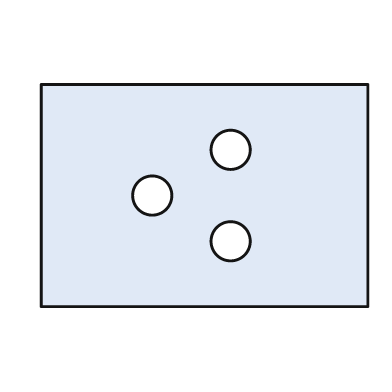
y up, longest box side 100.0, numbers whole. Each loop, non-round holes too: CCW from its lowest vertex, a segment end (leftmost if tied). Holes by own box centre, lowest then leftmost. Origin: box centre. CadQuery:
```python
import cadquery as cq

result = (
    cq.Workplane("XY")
    .moveTo(-50.0, -34.0)
    .lineTo(50.0, -34.0)
    .lineTo(50.0, 34.0)
    .lineTo(-50.0, 34.0)
    .close()
    .moveTo(8.0, -14.0)
    .circle(6.0)
    .moveTo(-16.0, 0.0)
    .circle(6.0)
    .moveTo(8.0, 14.0)
    .circle(6.0)
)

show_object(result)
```